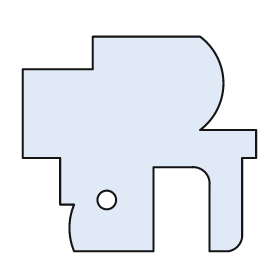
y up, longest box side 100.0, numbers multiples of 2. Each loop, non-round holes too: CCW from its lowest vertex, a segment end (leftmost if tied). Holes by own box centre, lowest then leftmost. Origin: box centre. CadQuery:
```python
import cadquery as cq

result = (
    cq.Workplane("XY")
    .moveTo(-28.0, -46.0)
    .lineTo(6.0, -46.0)
    .lineTo(6.0, -10.0)
    .lineTo(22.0, -10.0)
    .threePointArc((28.0, -12.0), (30.0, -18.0))
    .lineTo(30.0, -46.0)
    .lineTo(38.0, -46.0)
    .threePointArc((42.0, -44.0), (44.0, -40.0))
    .lineTo(44.0, -6.0)
    .lineTo(50.0, -6.0)
    .lineTo(50.0, 6.0)
    .lineTo(26.0, 6.0)
    .threePointArc((36.0, 26.0), (26.0, 46.0))
    .lineTo(-20.0, 46.0)
    .lineTo(-20.0, 32.0)
    .lineTo(-50.0, 32.0)
    .lineTo(-50.0, -6.0)
    .lineTo(-34.0, -6.0)
    .lineTo(-34.0, -26.0)
    .lineTo(-28.0, -26.0)
    .threePointArc((-30.0, -36.0), (-28.0, -46.0))
    .close()
    .moveTo(-14.0, -24.0)
    .circle(4.0)
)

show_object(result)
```